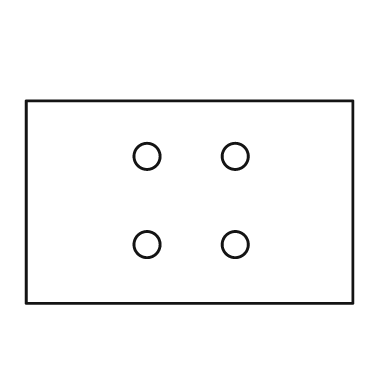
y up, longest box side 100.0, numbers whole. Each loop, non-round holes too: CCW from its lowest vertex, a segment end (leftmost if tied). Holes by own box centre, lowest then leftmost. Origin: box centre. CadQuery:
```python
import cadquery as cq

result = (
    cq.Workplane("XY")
    .moveTo(-50.0, -31.0)
    .lineTo(50.0, -31.0)
    .lineTo(50.0, 31.0)
    .lineTo(-50.0, 31.0)
    .close()
    .moveTo(-13.0, -13.0)
    .circle(4.0)
    .moveTo(14.0, -13.0)
    .circle(4.0)
    .moveTo(-13.0, 14.0)
    .circle(4.0)
    .moveTo(14.0, 14.0)
    .circle(4.0)
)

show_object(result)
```